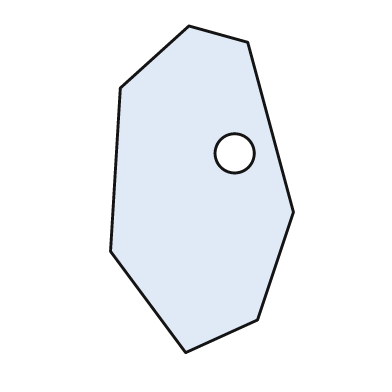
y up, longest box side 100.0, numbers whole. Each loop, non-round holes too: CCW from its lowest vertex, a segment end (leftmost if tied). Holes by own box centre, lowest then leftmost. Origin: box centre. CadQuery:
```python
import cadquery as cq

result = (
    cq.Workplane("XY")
    .moveTo(-5.0, -50.0)
    .lineTo(17.0, -40.0)
    .lineTo(28.0, -7.0)
    .lineTo(14.0, 45.0)
    .lineTo(-4.0, 50.0)
    .lineTo(-25.0, 31.0)
    .lineTo(-28.0, -19.0)
    .close()
    .moveTo(10.0, 11.0)
    .circle(6.0)
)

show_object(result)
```